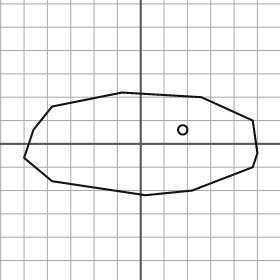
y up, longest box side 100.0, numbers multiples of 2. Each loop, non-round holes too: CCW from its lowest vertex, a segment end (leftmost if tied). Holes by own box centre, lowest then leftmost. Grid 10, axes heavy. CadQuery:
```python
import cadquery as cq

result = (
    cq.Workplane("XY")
    .moveTo(2.0, -22.0)
    .lineTo(22.0, -20.0)
    .lineTo(48.0, -10.0)
    .lineTo(50.0, -4.0)
    .lineTo(48.0, 10.0)
    .lineTo(26.0, 20.0)
    .lineTo(-8.0, 22.0)
    .lineTo(-38.0, 16.0)
    .lineTo(-46.0, 6.0)
    .lineTo(-50.0, -6.0)
    .lineTo(-38.0, -16.0)
    .close()
    .moveTo(18.0, 6.0)
    .circle(2.0)
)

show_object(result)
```